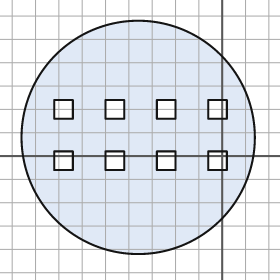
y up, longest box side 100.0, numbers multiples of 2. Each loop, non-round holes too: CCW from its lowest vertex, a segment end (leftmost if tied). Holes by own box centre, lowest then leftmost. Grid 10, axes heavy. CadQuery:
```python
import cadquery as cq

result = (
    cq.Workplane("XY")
    .moveTo(-36.0, 8.0)
    .circle(50.0)
    .moveTo(-72.0, -6.0)
    .lineTo(-64.0, -6.0)
    .lineTo(-64.0, 2.0)
    .lineTo(-72.0, 2.0)
    .close()
    .moveTo(-50.0, -6.0)
    .lineTo(-42.0, -6.0)
    .lineTo(-42.0, 2.0)
    .lineTo(-50.0, 2.0)
    .close()
    .moveTo(-28.0, -6.0)
    .lineTo(-20.0, -6.0)
    .lineTo(-20.0, 2.0)
    .lineTo(-28.0, 2.0)
    .close()
    .moveTo(-6.0, -6.0)
    .lineTo(2.0, -6.0)
    .lineTo(2.0, 2.0)
    .lineTo(-6.0, 2.0)
    .close()
    .moveTo(-72.0, 16.0)
    .lineTo(-64.0, 16.0)
    .lineTo(-64.0, 24.0)
    .lineTo(-72.0, 24.0)
    .close()
    .moveTo(-50.0, 16.0)
    .lineTo(-42.0, 16.0)
    .lineTo(-42.0, 24.0)
    .lineTo(-50.0, 24.0)
    .close()
    .moveTo(-28.0, 16.0)
    .lineTo(-20.0, 16.0)
    .lineTo(-20.0, 24.0)
    .lineTo(-28.0, 24.0)
    .close()
    .moveTo(-6.0, 16.0)
    .lineTo(2.0, 16.0)
    .lineTo(2.0, 24.0)
    .lineTo(-6.0, 24.0)
    .close()
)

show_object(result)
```